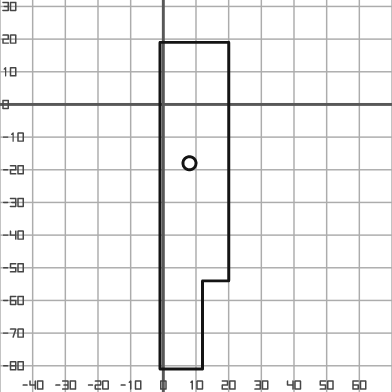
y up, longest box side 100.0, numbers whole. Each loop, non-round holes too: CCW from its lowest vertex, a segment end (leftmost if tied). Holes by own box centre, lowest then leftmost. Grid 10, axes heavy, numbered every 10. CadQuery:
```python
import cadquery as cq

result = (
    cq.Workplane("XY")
    .moveTo(-1.0, -81.0)
    .lineTo(12.0, -81.0)
    .lineTo(12.0, -54.0)
    .lineTo(20.0, -54.0)
    .lineTo(20.0, 19.0)
    .lineTo(-1.0, 19.0)
    .close()
    .moveTo(8.0, -18.0)
    .circle(2.0)
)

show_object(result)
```